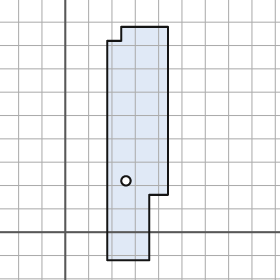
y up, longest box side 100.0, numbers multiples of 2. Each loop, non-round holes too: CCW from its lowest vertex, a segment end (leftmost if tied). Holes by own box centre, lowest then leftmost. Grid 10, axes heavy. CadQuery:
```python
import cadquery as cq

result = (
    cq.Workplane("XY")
    .moveTo(18.0, -12.0)
    .lineTo(36.0, -12.0)
    .lineTo(36.0, 16.0)
    .lineTo(44.0, 16.0)
    .lineTo(44.0, 88.0)
    .lineTo(24.0, 88.0)
    .lineTo(24.0, 82.0)
    .lineTo(18.0, 82.0)
    .close()
    .moveTo(26.0, 22.0)
    .circle(2.0)
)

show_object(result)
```